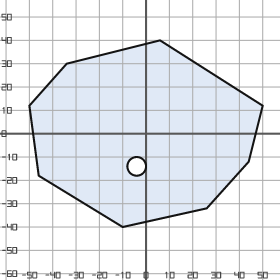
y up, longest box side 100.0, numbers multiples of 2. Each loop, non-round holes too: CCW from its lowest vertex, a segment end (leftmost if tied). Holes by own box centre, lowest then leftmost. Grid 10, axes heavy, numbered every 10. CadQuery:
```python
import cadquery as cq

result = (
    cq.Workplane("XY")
    .moveTo(-10.0, -40.0)
    .lineTo(26.0, -32.0)
    .lineTo(44.0, -12.0)
    .lineTo(50.0, 12.0)
    .lineTo(6.0, 40.0)
    .lineTo(-34.0, 30.0)
    .lineTo(-50.0, 12.0)
    .lineTo(-46.0, -18.0)
    .close()
    .moveTo(-4.0, -14.0)
    .circle(4.0)
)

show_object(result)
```